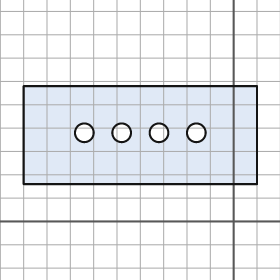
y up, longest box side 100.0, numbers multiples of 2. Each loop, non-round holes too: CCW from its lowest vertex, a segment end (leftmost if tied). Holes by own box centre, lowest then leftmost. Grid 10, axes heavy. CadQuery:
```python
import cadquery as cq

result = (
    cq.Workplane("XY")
    .moveTo(-90.0, 16.0)
    .lineTo(10.0, 16.0)
    .lineTo(10.0, 58.0)
    .lineTo(-90.0, 58.0)
    .close()
    .moveTo(-64.0, 38.0)
    .circle(4.0)
    .moveTo(-48.0, 38.0)
    .circle(4.0)
    .moveTo(-32.0, 38.0)
    .circle(4.0)
    .moveTo(-16.0, 38.0)
    .circle(4.0)
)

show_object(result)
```